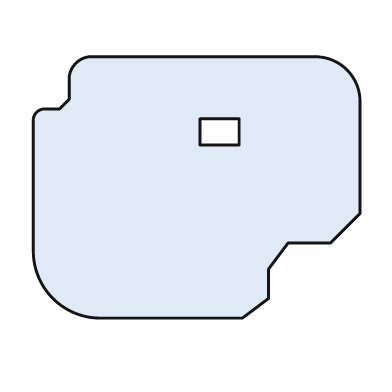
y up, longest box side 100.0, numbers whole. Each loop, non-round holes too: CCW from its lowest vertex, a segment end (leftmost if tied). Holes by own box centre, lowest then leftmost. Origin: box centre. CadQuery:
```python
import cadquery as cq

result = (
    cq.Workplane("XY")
    .moveTo(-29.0, -40.0)
    .lineTo(14.0, -40.0)
    .lineTo(22.0, -34.0)
    .lineTo(22.0, -25.0)
    .lineTo(28.0, -17.0)
    .lineTo(41.0, -17.0)
    .lineTo(50.0, -8.0)
    .lineTo(50.0, 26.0)
    .threePointArc((46.0, 36.0), (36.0, 40.0))
    .lineTo(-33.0, 40.0)
    .threePointArc((-37.0, 38.0), (-39.0, 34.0))
    .lineTo(-39.0, 27.0)
    .lineTo(-42.0, 24.0)
    .lineTo(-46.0, 24.0)
    .threePointArc((-49.0, 23.0), (-50.0, 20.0))
    .lineTo(-50.0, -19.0)
    .threePointArc((-44.0, -34.0), (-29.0, -40.0))
    .close()
    .moveTo(1.0, 13.0)
    .lineTo(13.0, 13.0)
    .lineTo(13.0, 21.0)
    .lineTo(1.0, 21.0)
    .close()
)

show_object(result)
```